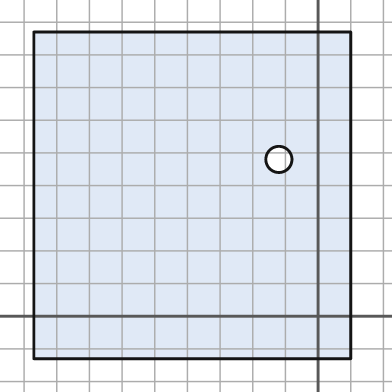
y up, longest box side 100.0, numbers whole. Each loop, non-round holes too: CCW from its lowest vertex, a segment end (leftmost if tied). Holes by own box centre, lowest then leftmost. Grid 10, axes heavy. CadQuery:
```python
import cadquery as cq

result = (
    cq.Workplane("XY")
    .moveTo(-87.0, -13.0)
    .lineTo(10.0, -13.0)
    .lineTo(10.0, 87.0)
    .lineTo(-87.0, 87.0)
    .close()
    .moveTo(-12.0, 48.0)
    .circle(4.0)
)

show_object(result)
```